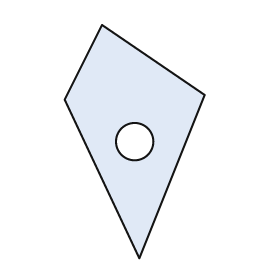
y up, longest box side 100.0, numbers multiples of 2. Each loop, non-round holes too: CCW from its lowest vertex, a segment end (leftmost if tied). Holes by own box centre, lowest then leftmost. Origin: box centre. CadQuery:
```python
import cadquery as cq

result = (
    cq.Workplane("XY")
    .moveTo(2.0, -50.0)
    .lineTo(30.0, 20.0)
    .lineTo(-14.0, 50.0)
    .lineTo(-30.0, 18.0)
    .close()
    .moveTo(0.0, 0.0)
    .circle(8.0)
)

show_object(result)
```